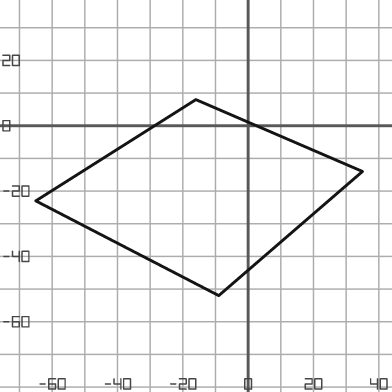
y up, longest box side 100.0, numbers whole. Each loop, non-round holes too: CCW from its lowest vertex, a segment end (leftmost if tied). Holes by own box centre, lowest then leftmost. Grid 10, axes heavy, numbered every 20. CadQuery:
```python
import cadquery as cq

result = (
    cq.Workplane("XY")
    .moveTo(-9.0, -52.0)
    .lineTo(35.0, -14.0)
    .lineTo(-16.0, 8.0)
    .lineTo(-65.0, -23.0)
    .close()
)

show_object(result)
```